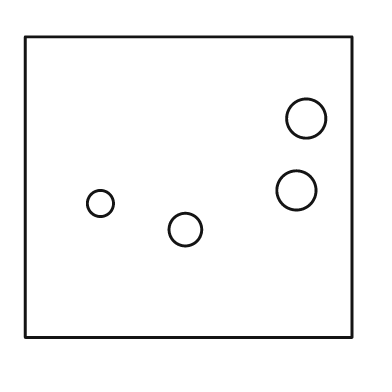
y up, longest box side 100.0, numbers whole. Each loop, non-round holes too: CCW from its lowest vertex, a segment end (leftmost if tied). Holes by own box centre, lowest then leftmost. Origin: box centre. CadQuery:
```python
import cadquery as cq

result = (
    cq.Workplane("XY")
    .moveTo(-50.0, -46.0)
    .lineTo(50.0, -46.0)
    .lineTo(50.0, 46.0)
    .lineTo(-50.0, 46.0)
    .close()
    .moveTo(-1.0, -13.0)
    .circle(5.0)
    .moveTo(-27.0, -5.0)
    .circle(4.0)
    .moveTo(33.0, -1.0)
    .circle(6.0)
    .moveTo(36.0, 21.0)
    .circle(6.0)
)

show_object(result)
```